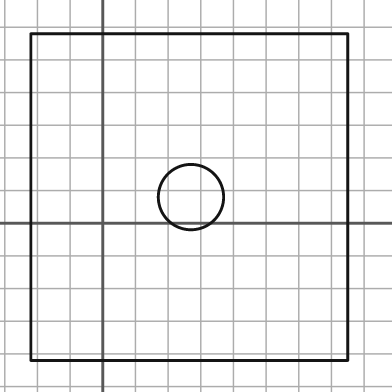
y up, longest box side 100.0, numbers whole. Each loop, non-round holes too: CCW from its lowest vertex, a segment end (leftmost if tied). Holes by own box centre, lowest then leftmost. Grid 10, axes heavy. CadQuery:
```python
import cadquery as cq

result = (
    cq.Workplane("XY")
    .moveTo(-22.0, -42.0)
    .lineTo(75.0, -42.0)
    .lineTo(75.0, 58.0)
    .lineTo(-22.0, 58.0)
    .close()
    .moveTo(27.0, 8.0)
    .circle(10.0)
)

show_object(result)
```